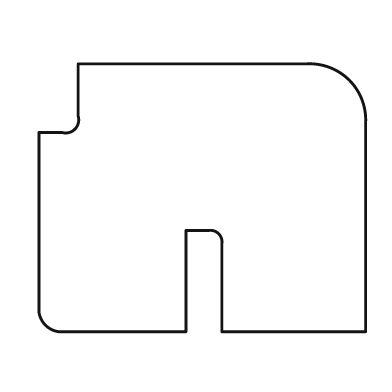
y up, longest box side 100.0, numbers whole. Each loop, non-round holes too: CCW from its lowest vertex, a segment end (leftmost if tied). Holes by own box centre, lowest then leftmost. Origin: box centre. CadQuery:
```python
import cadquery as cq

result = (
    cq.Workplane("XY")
    .moveTo(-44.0, -41.0)
    .lineTo(-5.0, -41.0)
    .lineTo(-5.0, -10.0)
    .lineTo(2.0, -10.0)
    .threePointArc((5.0, -11.0), (6.0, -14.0))
    .lineTo(6.0, -41.0)
    .lineTo(50.0, -41.0)
    .lineTo(50.0, 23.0)
    .threePointArc((45.0, 36.0), (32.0, 41.0))
    .lineTo(-38.0, 41.0)
    .lineTo(-38.0, 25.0)
    .threePointArc((-39.0, 21.0), (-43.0, 20.0))
    .lineTo(-50.0, 20.0)
    .lineTo(-50.0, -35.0)
    .threePointArc((-48.0, -39.0), (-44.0, -41.0))
    .close()
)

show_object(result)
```